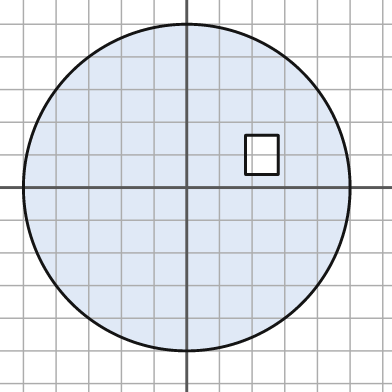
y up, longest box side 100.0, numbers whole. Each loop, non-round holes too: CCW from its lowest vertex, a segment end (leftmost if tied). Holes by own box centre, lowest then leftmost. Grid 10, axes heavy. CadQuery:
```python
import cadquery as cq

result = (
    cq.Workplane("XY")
    .moveTo(0.0, 0.0)
    .circle(50.0)
    .moveTo(18.0, 4.0)
    .lineTo(28.0, 4.0)
    .lineTo(28.0, 16.0)
    .lineTo(18.0, 16.0)
    .close()
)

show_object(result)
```